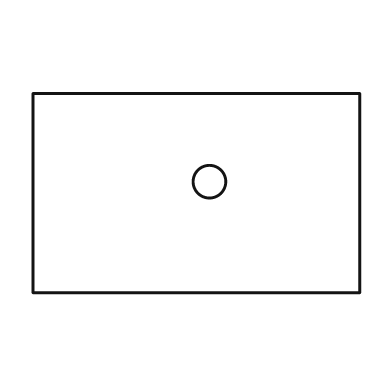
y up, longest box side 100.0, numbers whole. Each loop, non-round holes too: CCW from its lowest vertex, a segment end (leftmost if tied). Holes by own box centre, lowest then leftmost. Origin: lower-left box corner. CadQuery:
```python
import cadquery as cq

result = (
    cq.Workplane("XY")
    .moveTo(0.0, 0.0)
    .lineTo(100.0, 0.0)
    .lineTo(100.0, 61.0)
    .lineTo(0.0, 61.0)
    .close()
    .moveTo(54.0, 34.0)
    .circle(5.0)
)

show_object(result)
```